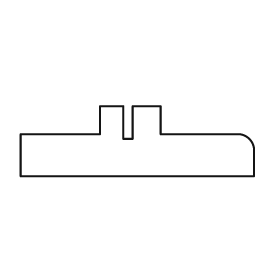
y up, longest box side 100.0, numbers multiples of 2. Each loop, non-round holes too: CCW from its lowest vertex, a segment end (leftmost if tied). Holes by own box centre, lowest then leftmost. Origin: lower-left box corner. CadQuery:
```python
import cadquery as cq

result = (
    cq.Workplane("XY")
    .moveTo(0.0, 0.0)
    .lineTo(100.0, 0.0)
    .lineTo(100.0, 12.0)
    .threePointArc((98.0, 16.0), (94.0, 18.0))
    .lineTo(60.0, 18.0)
    .lineTo(60.0, 30.0)
    .lineTo(48.0, 30.0)
    .lineTo(48.0, 16.0)
    .lineTo(44.0, 16.0)
    .lineTo(44.0, 30.0)
    .lineTo(34.0, 30.0)
    .lineTo(34.0, 18.0)
    .lineTo(0.0, 18.0)
    .close()
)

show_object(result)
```